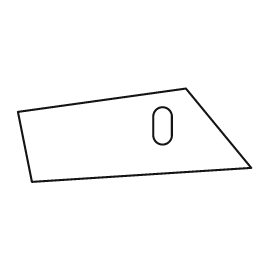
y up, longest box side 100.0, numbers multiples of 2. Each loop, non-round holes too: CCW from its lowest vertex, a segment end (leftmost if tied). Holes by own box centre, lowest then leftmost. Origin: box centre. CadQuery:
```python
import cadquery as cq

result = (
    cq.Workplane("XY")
    .moveTo(-44.0, -20.0)
    .lineTo(50.0, -14.0)
    .lineTo(22.0, 20.0)
    .lineTo(-50.0, 10.0)
    .close()
    .moveTo(8.0, 0.0)
    .threePointArc((12.0, -4.0), (16.0, 0.0))
    .lineTo(16.0, 8.0)
    .threePointArc((12.0, 12.0), (8.0, 8.0))
    .close()
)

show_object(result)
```